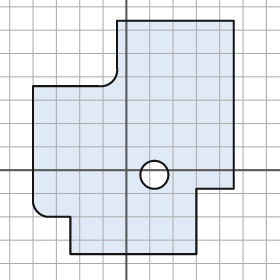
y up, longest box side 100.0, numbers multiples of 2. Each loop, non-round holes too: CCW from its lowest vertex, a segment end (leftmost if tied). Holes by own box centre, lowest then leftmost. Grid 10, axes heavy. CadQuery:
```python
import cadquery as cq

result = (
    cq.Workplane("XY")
    .moveTo(-24.0, -36.0)
    .lineTo(30.0, -36.0)
    .lineTo(30.0, -8.0)
    .lineTo(46.0, -8.0)
    .lineTo(46.0, 64.0)
    .lineTo(-4.0, 64.0)
    .lineTo(-4.0, 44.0)
    .threePointArc((-6.0, 38.0), (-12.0, 36.0))
    .lineTo(-40.0, 36.0)
    .lineTo(-40.0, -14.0)
    .threePointArc((-38.0, -18.0), (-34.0, -20.0))
    .lineTo(-24.0, -20.0)
    .close()
    .moveTo(12.0, -2.0)
    .circle(6.0)
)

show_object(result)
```